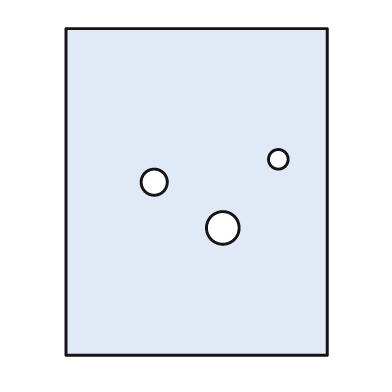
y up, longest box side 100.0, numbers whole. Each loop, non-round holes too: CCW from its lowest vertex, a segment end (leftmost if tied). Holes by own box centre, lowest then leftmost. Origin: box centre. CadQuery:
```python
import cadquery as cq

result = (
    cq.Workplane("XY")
    .moveTo(-40.0, -50.0)
    .lineTo(40.0, -50.0)
    .lineTo(40.0, 50.0)
    .lineTo(-40.0, 50.0)
    .close()
    .moveTo(8.0, -11.0)
    .circle(5.0)
    .moveTo(-13.0, 3.0)
    .circle(4.0)
    .moveTo(25.0, 10.0)
    .circle(3.0)
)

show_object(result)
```